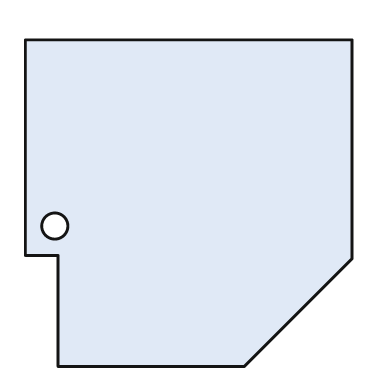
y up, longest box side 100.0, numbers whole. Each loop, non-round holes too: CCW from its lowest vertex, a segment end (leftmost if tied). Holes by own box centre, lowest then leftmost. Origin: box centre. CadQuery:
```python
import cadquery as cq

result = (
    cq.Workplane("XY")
    .moveTo(-40.0, -50.0)
    .lineTo(17.0, -50.0)
    .lineTo(50.0, -17.0)
    .lineTo(50.0, 50.0)
    .lineTo(-50.0, 50.0)
    .lineTo(-50.0, -16.0)
    .lineTo(-40.0, -16.0)
    .close()
    .moveTo(-41.0, -7.0)
    .circle(4.0)
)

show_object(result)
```